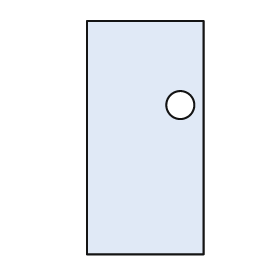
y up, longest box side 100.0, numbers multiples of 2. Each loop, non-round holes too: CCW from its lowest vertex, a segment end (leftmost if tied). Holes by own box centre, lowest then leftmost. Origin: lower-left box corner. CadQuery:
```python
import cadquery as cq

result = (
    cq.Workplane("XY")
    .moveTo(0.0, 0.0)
    .lineTo(50.0, 0.0)
    .lineTo(50.0, 100.0)
    .lineTo(0.0, 100.0)
    .close()
    .moveTo(40.0, 64.0)
    .circle(6.0)
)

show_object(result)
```